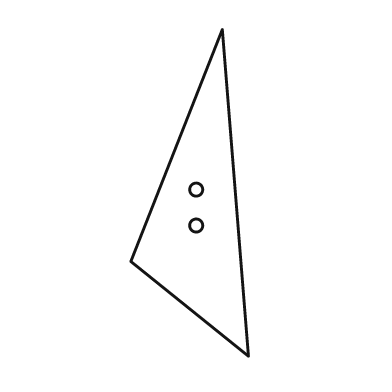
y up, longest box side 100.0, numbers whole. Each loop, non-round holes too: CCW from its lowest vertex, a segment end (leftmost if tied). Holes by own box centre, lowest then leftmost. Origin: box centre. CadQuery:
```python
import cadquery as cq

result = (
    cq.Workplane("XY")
    .moveTo(18.0, -50.0)
    .lineTo(10.0, 50.0)
    .lineTo(-18.0, -21.0)
    .close()
    .moveTo(2.0, -10.0)
    .circle(2.0)
    .moveTo(2.0, 1.0)
    .circle(2.0)
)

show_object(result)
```